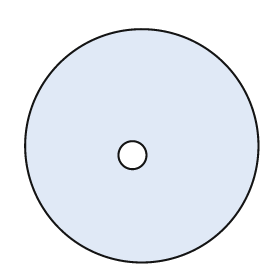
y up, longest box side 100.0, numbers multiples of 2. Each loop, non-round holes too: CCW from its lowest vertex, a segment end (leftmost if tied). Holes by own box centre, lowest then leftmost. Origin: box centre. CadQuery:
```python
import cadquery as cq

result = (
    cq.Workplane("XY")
    .moveTo(0.0, 0.0)
    .circle(50.0)
    .moveTo(-4.0, -4.0)
    .circle(6.0)
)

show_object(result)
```